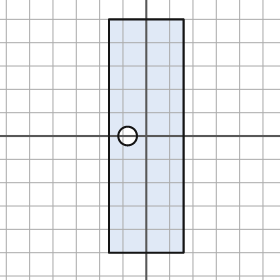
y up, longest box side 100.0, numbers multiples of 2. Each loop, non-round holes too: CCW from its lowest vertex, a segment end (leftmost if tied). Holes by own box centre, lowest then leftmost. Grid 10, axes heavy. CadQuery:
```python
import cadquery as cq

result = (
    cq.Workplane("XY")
    .moveTo(-16.0, -50.0)
    .lineTo(16.0, -50.0)
    .lineTo(16.0, 50.0)
    .lineTo(-16.0, 50.0)
    .close()
    .moveTo(-8.0, 0.0)
    .circle(4.0)
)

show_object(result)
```